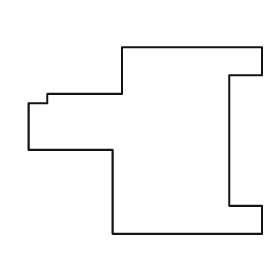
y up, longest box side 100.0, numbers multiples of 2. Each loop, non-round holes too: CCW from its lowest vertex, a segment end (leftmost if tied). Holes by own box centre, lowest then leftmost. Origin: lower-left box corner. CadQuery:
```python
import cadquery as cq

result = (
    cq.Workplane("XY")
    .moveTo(36.0, 0.0)
    .lineTo(100.0, 0.0)
    .lineTo(100.0, 12.0)
    .lineTo(86.0, 12.0)
    .lineTo(86.0, 68.0)
    .lineTo(100.0, 68.0)
    .lineTo(100.0, 80.0)
    .lineTo(40.0, 80.0)
    .lineTo(40.0, 60.0)
    .lineTo(8.0, 60.0)
    .lineTo(8.0, 56.0)
    .lineTo(0.0, 56.0)
    .lineTo(0.0, 36.0)
    .lineTo(36.0, 36.0)
    .close()
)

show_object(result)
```